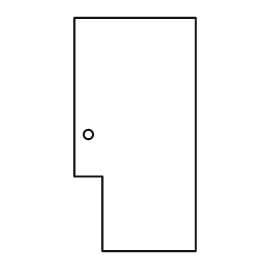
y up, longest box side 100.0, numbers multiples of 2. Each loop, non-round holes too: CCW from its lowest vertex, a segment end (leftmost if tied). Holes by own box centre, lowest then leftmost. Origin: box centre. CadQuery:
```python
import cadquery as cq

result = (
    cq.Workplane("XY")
    .moveTo(-14.0, -50.0)
    .lineTo(26.0, -50.0)
    .lineTo(26.0, 50.0)
    .lineTo(-26.0, 50.0)
    .lineTo(-26.0, -18.0)
    .lineTo(-14.0, -18.0)
    .close()
    .moveTo(-20.0, 0.0)
    .circle(2.0)
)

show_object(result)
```